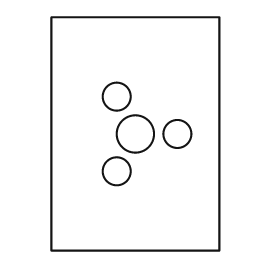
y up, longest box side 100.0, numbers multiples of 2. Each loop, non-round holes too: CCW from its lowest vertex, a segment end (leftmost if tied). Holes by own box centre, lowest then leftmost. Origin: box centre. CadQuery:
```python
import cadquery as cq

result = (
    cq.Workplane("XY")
    .moveTo(-36.0, -50.0)
    .lineTo(36.0, -50.0)
    .lineTo(36.0, 50.0)
    .lineTo(-36.0, 50.0)
    .close()
    .moveTo(-8.0, -16.0)
    .circle(6.0)
    .moveTo(0.0, 0.0)
    .circle(8.0)
    .moveTo(18.0, 0.0)
    .circle(6.0)
    .moveTo(-8.0, 16.0)
    .circle(6.0)
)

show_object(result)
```